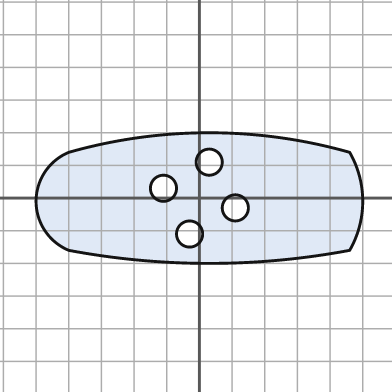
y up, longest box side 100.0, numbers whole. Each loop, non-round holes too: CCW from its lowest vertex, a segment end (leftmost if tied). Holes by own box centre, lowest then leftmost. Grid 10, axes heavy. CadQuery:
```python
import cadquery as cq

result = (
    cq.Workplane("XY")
    .moveTo(-40.0, -16.0)
    .threePointArc((3.0, -20.0), (46.0, -16.0))
    .threePointArc((50.0, -1.0), (46.0, 14.0))
    .threePointArc((3.0, 20.0), (-40.0, 14.0))
    .threePointArc((-50.0, -1.0), (-40.0, -16.0))
    .close()
    .moveTo(-3.0, -11.0)
    .circle(4.0)
    .moveTo(11.0, -3.0)
    .circle(4.0)
    .moveTo(-11.0, 3.0)
    .circle(4.0)
    .moveTo(3.0, 11.0)
    .circle(4.0)
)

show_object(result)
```